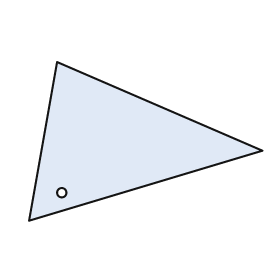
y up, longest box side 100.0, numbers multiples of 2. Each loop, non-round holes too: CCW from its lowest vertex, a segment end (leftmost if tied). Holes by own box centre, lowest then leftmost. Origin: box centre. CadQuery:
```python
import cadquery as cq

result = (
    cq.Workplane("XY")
    .moveTo(-50.0, -34.0)
    .lineTo(50.0, -4.0)
    .lineTo(-38.0, 34.0)
    .close()
    .moveTo(-36.0, -22.0)
    .circle(2.0)
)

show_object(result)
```